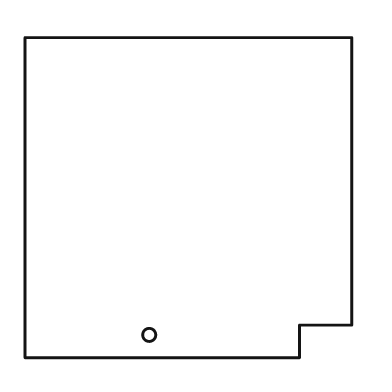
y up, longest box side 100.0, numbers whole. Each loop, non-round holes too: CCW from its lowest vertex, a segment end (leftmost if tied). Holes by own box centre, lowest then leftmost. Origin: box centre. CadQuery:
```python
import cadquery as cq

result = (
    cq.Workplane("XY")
    .moveTo(-50.0, -49.0)
    .lineTo(34.0, -49.0)
    .lineTo(34.0, -39.0)
    .lineTo(50.0, -39.0)
    .lineTo(50.0, 49.0)
    .lineTo(-50.0, 49.0)
    .close()
    .moveTo(-12.0, -42.0)
    .circle(2.0)
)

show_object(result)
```